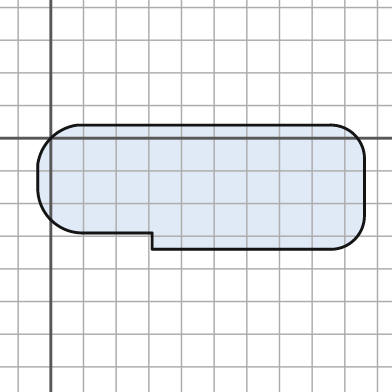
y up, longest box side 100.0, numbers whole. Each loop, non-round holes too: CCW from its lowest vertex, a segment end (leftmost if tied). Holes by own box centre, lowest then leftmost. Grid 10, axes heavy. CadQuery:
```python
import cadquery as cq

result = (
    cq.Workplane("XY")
    .moveTo(31.0, -34.0)
    .lineTo(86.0, -34.0)
    .threePointArc((93.0, -31.0), (96.0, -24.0))
    .lineTo(96.0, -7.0)
    .threePointArc((93.0, 1.0), (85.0, 4.0))
    .lineTo(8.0, 4.0)
    .threePointArc((0.0, 0.0), (-4.0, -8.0))
    .lineTo(-4.0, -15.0)
    .threePointArc((0.0, -25.0), (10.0, -29.0))
    .lineTo(31.0, -29.0)
    .close()
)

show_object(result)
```